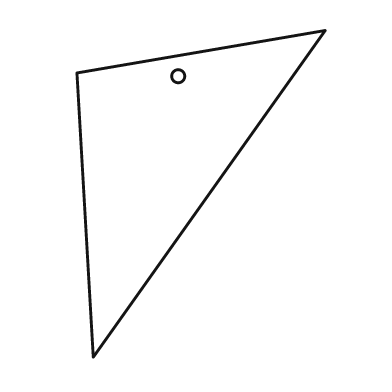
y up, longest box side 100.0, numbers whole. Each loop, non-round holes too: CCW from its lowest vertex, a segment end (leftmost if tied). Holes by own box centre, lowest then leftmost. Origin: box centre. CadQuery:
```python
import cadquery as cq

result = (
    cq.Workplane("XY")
    .moveTo(-33.0, -50.0)
    .lineTo(38.0, 50.0)
    .lineTo(-38.0, 37.0)
    .close()
    .moveTo(-7.0, 36.0)
    .circle(2.0)
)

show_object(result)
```